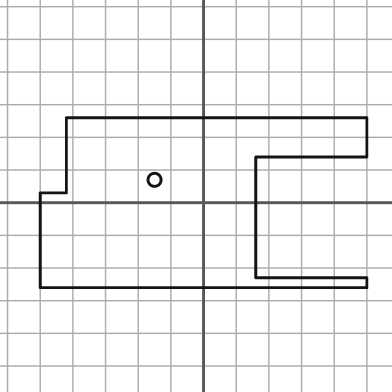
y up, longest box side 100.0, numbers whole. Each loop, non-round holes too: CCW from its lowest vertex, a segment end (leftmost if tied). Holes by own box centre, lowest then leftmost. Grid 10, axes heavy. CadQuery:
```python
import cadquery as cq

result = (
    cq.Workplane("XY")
    .moveTo(-50.0, -26.0)
    .lineTo(50.0, -26.0)
    .lineTo(50.0, -23.0)
    .lineTo(16.0, -23.0)
    .lineTo(16.0, 14.0)
    .lineTo(50.0, 14.0)
    .lineTo(50.0, 26.0)
    .lineTo(-42.0, 26.0)
    .lineTo(-42.0, 3.0)
    .lineTo(-50.0, 3.0)
    .close()
    .moveTo(-15.0, 7.0)
    .circle(2.0)
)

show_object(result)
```